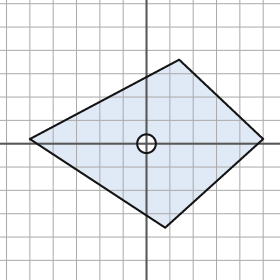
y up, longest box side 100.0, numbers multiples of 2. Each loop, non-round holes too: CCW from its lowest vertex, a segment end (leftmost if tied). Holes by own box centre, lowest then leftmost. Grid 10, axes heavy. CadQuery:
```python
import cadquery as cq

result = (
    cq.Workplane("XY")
    .moveTo(8.0, -36.0)
    .lineTo(50.0, 2.0)
    .lineTo(14.0, 36.0)
    .lineTo(-50.0, 2.0)
    .close()
    .moveTo(0.0, 0.0)
    .circle(4.0)
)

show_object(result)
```